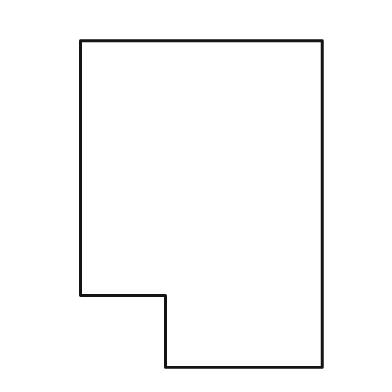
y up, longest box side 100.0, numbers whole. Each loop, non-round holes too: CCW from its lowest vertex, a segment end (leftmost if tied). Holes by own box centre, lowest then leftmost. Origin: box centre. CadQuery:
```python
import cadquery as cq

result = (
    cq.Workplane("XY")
    .moveTo(-11.0, -50.0)
    .lineTo(37.0, -50.0)
    .lineTo(37.0, 50.0)
    .lineTo(-37.0, 50.0)
    .lineTo(-37.0, -28.0)
    .lineTo(-11.0, -28.0)
    .close()
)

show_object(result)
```